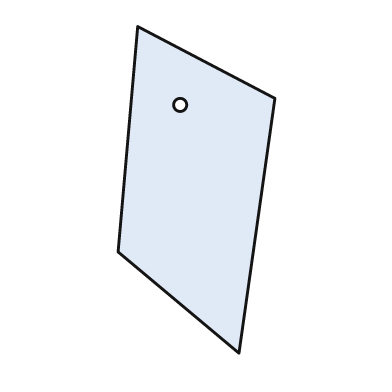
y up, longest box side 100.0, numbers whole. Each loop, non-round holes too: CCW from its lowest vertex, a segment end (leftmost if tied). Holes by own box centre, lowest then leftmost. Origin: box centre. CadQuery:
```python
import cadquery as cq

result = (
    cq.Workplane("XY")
    .moveTo(13.0, -50.0)
    .lineTo(24.0, 28.0)
    .lineTo(-18.0, 50.0)
    .lineTo(-24.0, -19.0)
    .close()
    .moveTo(-5.0, 26.0)
    .circle(2.0)
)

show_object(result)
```